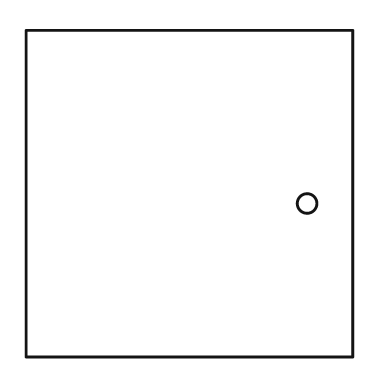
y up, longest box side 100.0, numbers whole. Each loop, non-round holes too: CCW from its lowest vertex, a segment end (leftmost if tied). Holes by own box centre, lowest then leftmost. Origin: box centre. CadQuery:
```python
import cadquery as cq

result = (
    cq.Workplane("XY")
    .moveTo(-50.0, -50.0)
    .lineTo(50.0, -50.0)
    .lineTo(50.0, 50.0)
    .lineTo(-50.0, 50.0)
    .close()
    .moveTo(36.0, -3.0)
    .circle(3.0)
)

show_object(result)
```